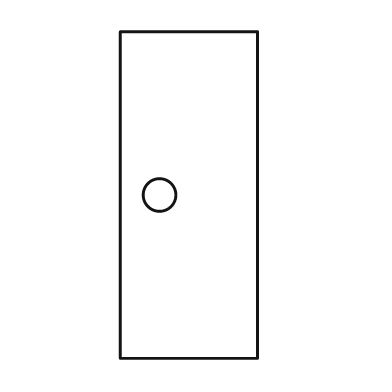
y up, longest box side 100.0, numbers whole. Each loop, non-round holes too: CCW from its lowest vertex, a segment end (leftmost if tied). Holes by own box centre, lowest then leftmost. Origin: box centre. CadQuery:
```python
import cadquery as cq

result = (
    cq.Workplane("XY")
    .moveTo(-21.0, -50.0)
    .lineTo(21.0, -50.0)
    .lineTo(21.0, 50.0)
    .lineTo(-21.0, 50.0)
    .close()
    .moveTo(-9.0, 0.0)
    .circle(5.0)
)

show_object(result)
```